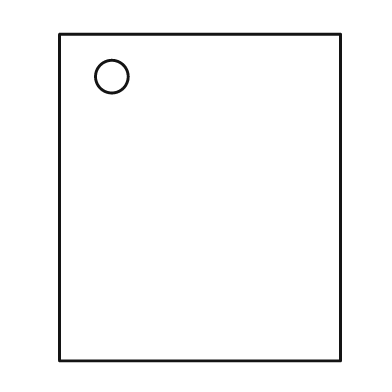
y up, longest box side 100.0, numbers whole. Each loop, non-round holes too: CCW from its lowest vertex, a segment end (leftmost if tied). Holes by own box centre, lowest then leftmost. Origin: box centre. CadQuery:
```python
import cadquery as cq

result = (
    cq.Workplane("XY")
    .moveTo(-43.0, -50.0)
    .lineTo(43.0, -50.0)
    .lineTo(43.0, 50.0)
    .lineTo(-43.0, 50.0)
    .close()
    .moveTo(-27.0, 37.0)
    .circle(5.0)
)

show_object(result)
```